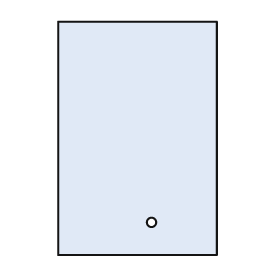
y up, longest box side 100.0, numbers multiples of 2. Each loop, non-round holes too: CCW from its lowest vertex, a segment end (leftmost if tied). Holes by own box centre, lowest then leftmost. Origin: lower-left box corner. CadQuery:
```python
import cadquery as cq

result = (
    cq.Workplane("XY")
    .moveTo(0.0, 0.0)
    .lineTo(68.0, 0.0)
    .lineTo(68.0, 100.0)
    .lineTo(0.0, 100.0)
    .close()
    .moveTo(40.0, 14.0)
    .circle(2.0)
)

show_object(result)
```